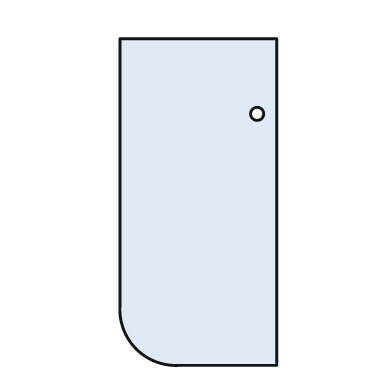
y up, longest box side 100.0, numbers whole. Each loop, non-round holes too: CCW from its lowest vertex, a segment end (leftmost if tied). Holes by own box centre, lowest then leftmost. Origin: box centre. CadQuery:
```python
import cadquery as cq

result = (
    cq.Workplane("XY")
    .moveTo(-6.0, -50.0)
    .lineTo(24.0, -50.0)
    .lineTo(24.0, 50.0)
    .lineTo(-24.0, 50.0)
    .lineTo(-24.0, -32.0)
    .threePointArc((-19.0, -45.0), (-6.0, -50.0))
    .close()
    .moveTo(18.0, 27.0)
    .circle(2.0)
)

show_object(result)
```